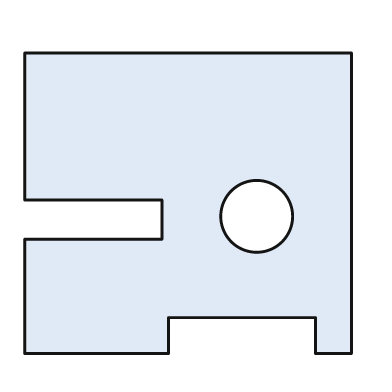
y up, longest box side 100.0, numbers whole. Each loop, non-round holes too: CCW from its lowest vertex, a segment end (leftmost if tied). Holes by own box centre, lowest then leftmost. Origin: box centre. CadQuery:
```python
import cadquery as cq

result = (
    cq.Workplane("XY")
    .moveTo(-50.0, -46.0)
    .lineTo(-6.0, -46.0)
    .lineTo(-6.0, -35.0)
    .lineTo(39.0, -35.0)
    .lineTo(39.0, -46.0)
    .lineTo(50.0, -46.0)
    .lineTo(50.0, 46.0)
    .lineTo(-50.0, 46.0)
    .lineTo(-50.0, 1.0)
    .lineTo(-8.0, 1.0)
    .lineTo(-8.0, -11.0)
    .lineTo(-50.0, -11.0)
    .close()
    .moveTo(21.0, -4.0)
    .circle(11.0)
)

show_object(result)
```